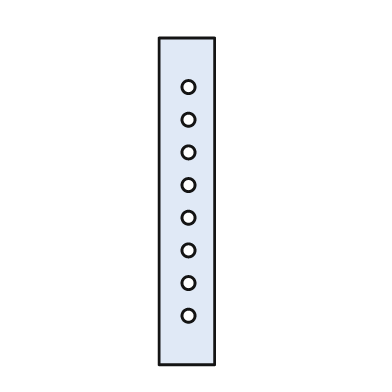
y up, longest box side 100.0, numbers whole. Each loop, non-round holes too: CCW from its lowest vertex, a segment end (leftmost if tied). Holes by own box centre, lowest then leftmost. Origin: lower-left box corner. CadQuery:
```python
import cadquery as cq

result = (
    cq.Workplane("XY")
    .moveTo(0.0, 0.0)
    .lineTo(17.0, 0.0)
    .lineTo(17.0, 100.0)
    .lineTo(0.0, 100.0)
    .close()
    .moveTo(9.0, 15.0)
    .circle(2.0)
    .moveTo(9.0, 25.0)
    .circle(2.0)
    .moveTo(9.0, 35.0)
    .circle(2.0)
    .moveTo(9.0, 45.0)
    .circle(2.0)
    .moveTo(9.0, 55.0)
    .circle(2.0)
    .moveTo(9.0, 65.0)
    .circle(2.0)
    .moveTo(9.0, 75.0)
    .circle(2.0)
    .moveTo(9.0, 85.0)
    .circle(2.0)
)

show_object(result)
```